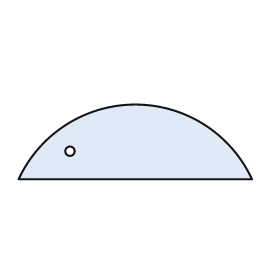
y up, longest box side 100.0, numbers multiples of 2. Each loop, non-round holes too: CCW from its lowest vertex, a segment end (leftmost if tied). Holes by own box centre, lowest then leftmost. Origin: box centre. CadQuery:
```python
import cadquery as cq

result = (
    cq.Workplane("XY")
    .moveTo(-50.0, -16.0)
    .lineTo(50.0, -16.0)
    .threePointArc((0.0, 16.0), (-50.0, -16.0))
    .close()
    .moveTo(-28.0, -4.0)
    .circle(2.0)
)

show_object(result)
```